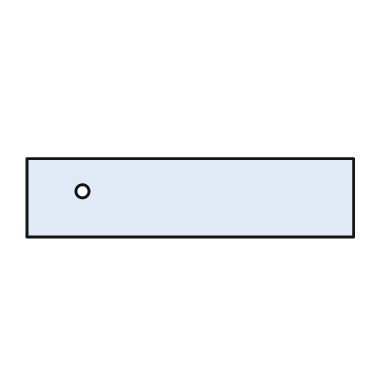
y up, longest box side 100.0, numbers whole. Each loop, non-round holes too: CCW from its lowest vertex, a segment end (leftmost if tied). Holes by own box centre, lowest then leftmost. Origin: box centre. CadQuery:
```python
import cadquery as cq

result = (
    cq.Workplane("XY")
    .moveTo(-50.0, -12.0)
    .lineTo(50.0, -12.0)
    .lineTo(50.0, 12.0)
    .lineTo(-50.0, 12.0)
    .close()
    .moveTo(-33.0, 2.0)
    .circle(2.0)
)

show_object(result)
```